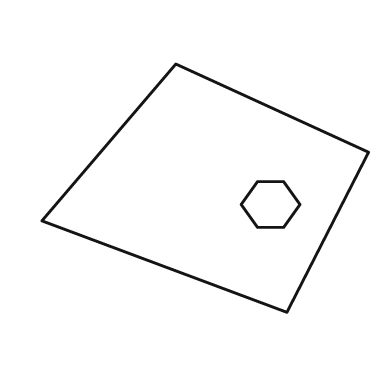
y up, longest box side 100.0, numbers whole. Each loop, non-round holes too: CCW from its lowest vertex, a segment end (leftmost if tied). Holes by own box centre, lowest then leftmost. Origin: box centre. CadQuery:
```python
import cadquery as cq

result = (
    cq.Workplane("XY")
    .moveTo(25.0, -38.0)
    .lineTo(50.0, 11.0)
    .lineTo(-9.0, 38.0)
    .lineTo(-50.0, -10.0)
    .close()
    .moveTo(16.0, -12.0)
    .lineTo(24.0, -12.0)
    .lineTo(29.0, -5.0)
    .lineTo(24.0, 2.0)
    .lineTo(16.0, 2.0)
    .lineTo(11.0, -5.0)
    .close()
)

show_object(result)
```